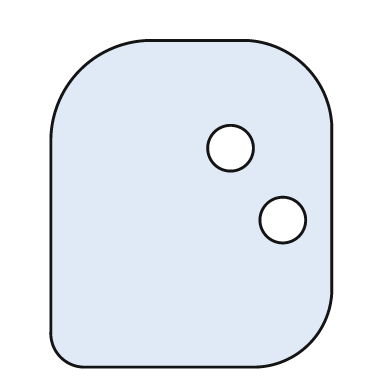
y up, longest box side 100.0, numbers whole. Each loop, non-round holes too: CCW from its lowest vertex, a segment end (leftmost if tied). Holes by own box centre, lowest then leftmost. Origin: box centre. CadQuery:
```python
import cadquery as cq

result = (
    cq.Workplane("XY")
    .moveTo(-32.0, -50.0)
    .lineTo(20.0, -50.0)
    .threePointArc((36.0, -43.0), (43.0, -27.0))
    .lineTo(43.0, 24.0)
    .threePointArc((35.0, 42.0), (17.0, 50.0))
    .lineTo(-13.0, 50.0)
    .threePointArc((-34.0, 41.0), (-43.0, 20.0))
    .lineTo(-43.0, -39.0)
    .threePointArc((-40.0, -47.0), (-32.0, -50.0))
    .close()
    .moveTo(28.0, -5.0)
    .circle(7.0)
    .moveTo(12.0, 17.0)
    .circle(7.0)
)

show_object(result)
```